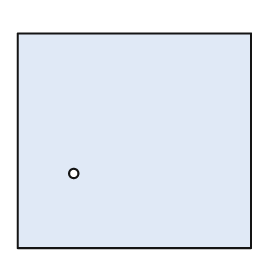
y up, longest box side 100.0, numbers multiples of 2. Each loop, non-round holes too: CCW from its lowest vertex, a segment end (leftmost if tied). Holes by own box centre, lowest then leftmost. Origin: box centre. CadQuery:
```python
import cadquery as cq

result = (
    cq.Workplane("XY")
    .moveTo(-50.0, -46.0)
    .lineTo(50.0, -46.0)
    .lineTo(50.0, 46.0)
    .lineTo(-50.0, 46.0)
    .close()
    .moveTo(-26.0, -14.0)
    .circle(2.0)
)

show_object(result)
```